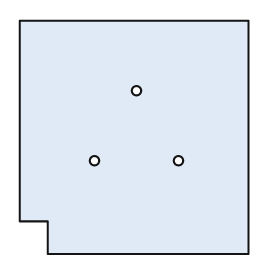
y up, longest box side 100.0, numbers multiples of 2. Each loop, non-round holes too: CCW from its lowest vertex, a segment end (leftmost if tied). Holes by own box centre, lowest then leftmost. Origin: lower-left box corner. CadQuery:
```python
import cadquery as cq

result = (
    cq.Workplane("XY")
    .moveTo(12.0, 0.0)
    .lineTo(98.0, 0.0)
    .lineTo(98.0, 100.0)
    .lineTo(0.0, 100.0)
    .lineTo(0.0, 14.0)
    .lineTo(12.0, 14.0)
    .close()
    .moveTo(32.0, 40.0)
    .circle(2.0)
    .moveTo(68.0, 40.0)
    .circle(2.0)
    .moveTo(50.0, 70.0)
    .circle(2.0)
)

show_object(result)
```